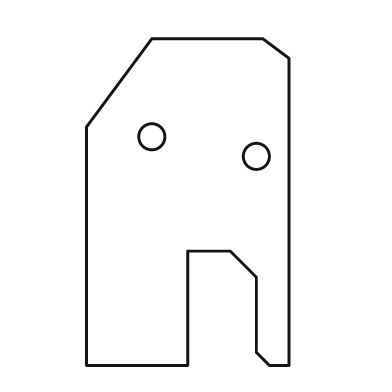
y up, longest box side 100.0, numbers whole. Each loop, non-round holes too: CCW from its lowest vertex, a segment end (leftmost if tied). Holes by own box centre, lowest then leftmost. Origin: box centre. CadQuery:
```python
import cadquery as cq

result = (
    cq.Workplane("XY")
    .moveTo(-31.0, -50.0)
    .lineTo(0.0, -50.0)
    .lineTo(0.0, -15.0)
    .lineTo(13.0, -15.0)
    .lineTo(21.0, -23.0)
    .lineTo(21.0, -46.0)
    .lineTo(25.0, -50.0)
    .lineTo(31.0, -50.0)
    .lineTo(31.0, 44.0)
    .lineTo(23.0, 50.0)
    .lineTo(-11.0, 50.0)
    .lineTo(-31.0, 23.0)
    .close()
    .moveTo(21.0, 14.0)
    .circle(4.0)
    .moveTo(-11.0, 20.0)
    .circle(4.0)
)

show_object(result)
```